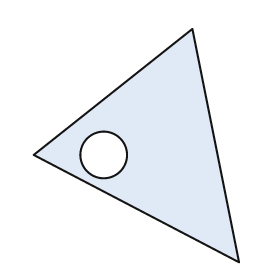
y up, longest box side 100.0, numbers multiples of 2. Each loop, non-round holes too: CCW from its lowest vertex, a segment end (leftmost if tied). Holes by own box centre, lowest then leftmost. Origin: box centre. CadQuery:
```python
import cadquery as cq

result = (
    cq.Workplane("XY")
    .moveTo(44.0, -50.0)
    .lineTo(24.0, 50.0)
    .lineTo(-44.0, -4.0)
    .close()
    .moveTo(-14.0, -4.0)
    .circle(10.0)
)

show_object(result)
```